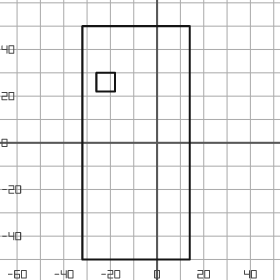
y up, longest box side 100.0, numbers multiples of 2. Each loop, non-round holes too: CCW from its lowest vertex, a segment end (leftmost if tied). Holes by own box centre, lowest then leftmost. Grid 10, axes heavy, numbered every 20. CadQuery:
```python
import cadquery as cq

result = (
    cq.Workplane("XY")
    .moveTo(-32.0, -50.0)
    .lineTo(14.0, -50.0)
    .lineTo(14.0, 50.0)
    .lineTo(-32.0, 50.0)
    .close()
    .moveTo(-26.0, 22.0)
    .lineTo(-18.0, 22.0)
    .lineTo(-18.0, 30.0)
    .lineTo(-26.0, 30.0)
    .close()
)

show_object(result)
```